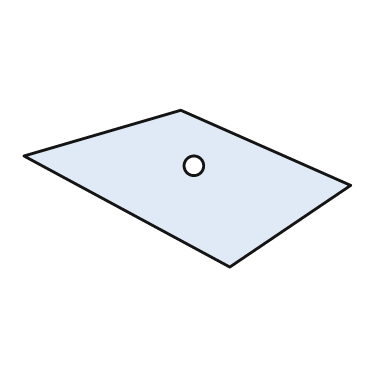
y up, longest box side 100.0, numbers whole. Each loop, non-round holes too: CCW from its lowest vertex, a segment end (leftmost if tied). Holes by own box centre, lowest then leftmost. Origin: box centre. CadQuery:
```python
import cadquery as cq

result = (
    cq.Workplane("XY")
    .moveTo(13.0, -24.0)
    .lineTo(50.0, 1.0)
    .lineTo(-2.0, 24.0)
    .lineTo(-50.0, 10.0)
    .close()
    .moveTo(2.0, 7.0)
    .circle(3.0)
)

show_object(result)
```